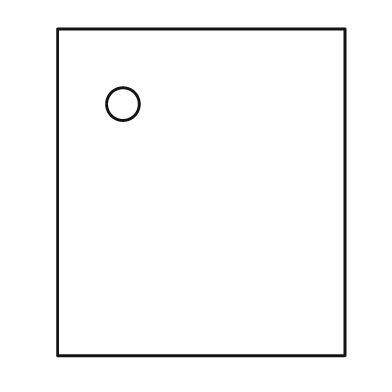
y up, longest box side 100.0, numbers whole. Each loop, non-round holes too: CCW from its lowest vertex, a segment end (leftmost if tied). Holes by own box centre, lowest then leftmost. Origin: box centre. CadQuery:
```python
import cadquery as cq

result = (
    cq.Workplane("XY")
    .moveTo(-44.0, -50.0)
    .lineTo(44.0, -50.0)
    .lineTo(44.0, 50.0)
    .lineTo(-44.0, 50.0)
    .close()
    .moveTo(-24.0, 27.0)
    .circle(5.0)
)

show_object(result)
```